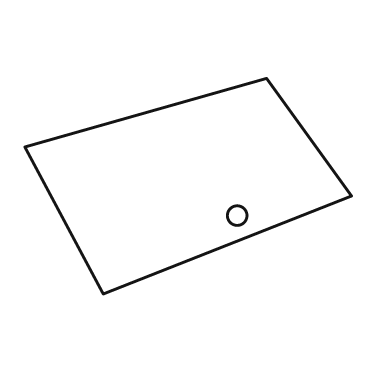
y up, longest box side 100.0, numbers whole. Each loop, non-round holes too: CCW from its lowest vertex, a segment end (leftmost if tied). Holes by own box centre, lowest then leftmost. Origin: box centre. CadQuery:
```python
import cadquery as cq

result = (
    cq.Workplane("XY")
    .moveTo(-26.0, -33.0)
    .lineTo(50.0, -3.0)
    .lineTo(24.0, 33.0)
    .lineTo(-50.0, 12.0)
    .close()
    .moveTo(15.0, -9.0)
    .circle(3.0)
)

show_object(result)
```